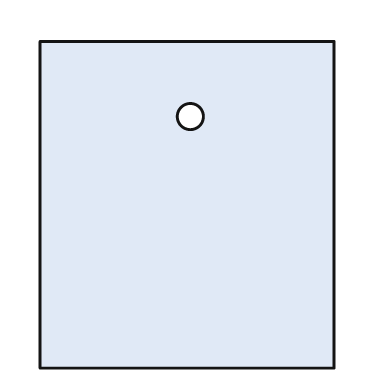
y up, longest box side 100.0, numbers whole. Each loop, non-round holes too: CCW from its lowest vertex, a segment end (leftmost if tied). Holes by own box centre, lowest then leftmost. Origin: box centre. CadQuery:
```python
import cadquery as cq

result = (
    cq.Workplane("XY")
    .moveTo(-45.0, -50.0)
    .lineTo(45.0, -50.0)
    .lineTo(45.0, 50.0)
    .lineTo(-45.0, 50.0)
    .close()
    .moveTo(1.0, 27.0)
    .circle(4.0)
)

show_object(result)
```